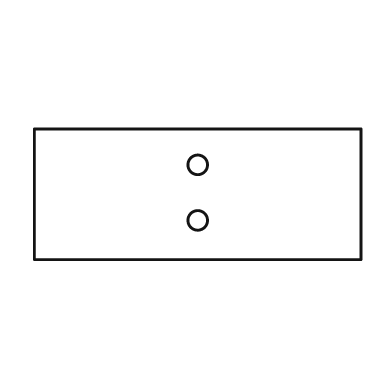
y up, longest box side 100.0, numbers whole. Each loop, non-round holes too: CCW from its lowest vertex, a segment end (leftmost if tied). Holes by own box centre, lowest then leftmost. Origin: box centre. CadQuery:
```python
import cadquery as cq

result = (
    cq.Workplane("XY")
    .moveTo(-50.0, -20.0)
    .lineTo(50.0, -20.0)
    .lineTo(50.0, 20.0)
    .lineTo(-50.0, 20.0)
    .close()
    .moveTo(0.0, -8.0)
    .circle(3.0)
    .moveTo(0.0, 9.0)
    .circle(3.0)
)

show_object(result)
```